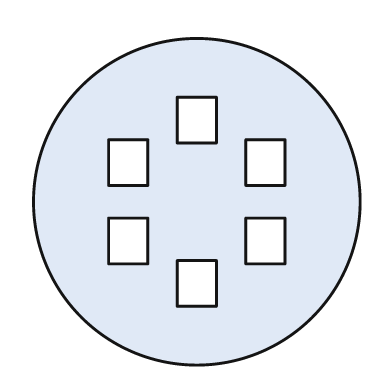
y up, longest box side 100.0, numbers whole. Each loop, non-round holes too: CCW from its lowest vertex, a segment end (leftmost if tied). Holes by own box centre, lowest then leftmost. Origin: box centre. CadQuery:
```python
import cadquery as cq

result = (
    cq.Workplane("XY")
    .moveTo(0.0, 0.0)
    .circle(50.0)
    .moveTo(-6.0, -32.0)
    .lineTo(6.0, -32.0)
    .lineTo(6.0, -18.0)
    .lineTo(-6.0, -18.0)
    .close()
    .moveTo(-27.0, -19.0)
    .lineTo(-15.0, -19.0)
    .lineTo(-15.0, -5.0)
    .lineTo(-27.0, -5.0)
    .close()
    .moveTo(15.0, -19.0)
    .lineTo(27.0, -19.0)
    .lineTo(27.0, -5.0)
    .lineTo(15.0, -5.0)
    .close()
    .moveTo(-27.0, 5.0)
    .lineTo(-15.0, 5.0)
    .lineTo(-15.0, 19.0)
    .lineTo(-27.0, 19.0)
    .close()
    .moveTo(15.0, 5.0)
    .lineTo(27.0, 5.0)
    .lineTo(27.0, 19.0)
    .lineTo(15.0, 19.0)
    .close()
    .moveTo(-6.0, 18.0)
    .lineTo(6.0, 18.0)
    .lineTo(6.0, 32.0)
    .lineTo(-6.0, 32.0)
    .close()
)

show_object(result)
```